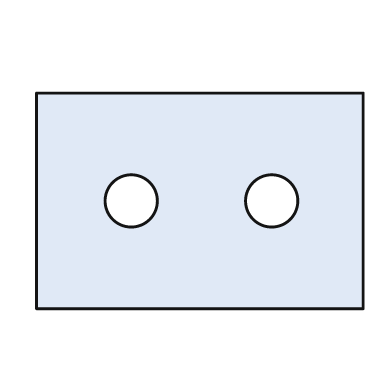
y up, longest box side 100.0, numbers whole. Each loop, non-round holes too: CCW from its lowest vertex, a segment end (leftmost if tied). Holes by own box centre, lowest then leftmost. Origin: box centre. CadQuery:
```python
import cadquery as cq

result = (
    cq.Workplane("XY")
    .moveTo(-50.0, -33.0)
    .lineTo(50.0, -33.0)
    .lineTo(50.0, 33.0)
    .lineTo(-50.0, 33.0)
    .close()
    .moveTo(-21.0, 0.0)
    .circle(8.0)
    .moveTo(22.0, 0.0)
    .circle(8.0)
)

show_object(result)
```